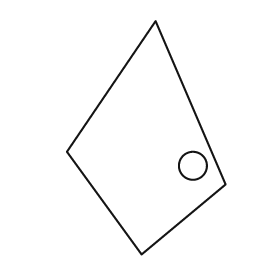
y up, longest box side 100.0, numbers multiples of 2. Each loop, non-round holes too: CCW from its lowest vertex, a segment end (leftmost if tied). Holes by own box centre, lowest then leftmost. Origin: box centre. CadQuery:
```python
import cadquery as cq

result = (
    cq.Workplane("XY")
    .moveTo(-2.0, -50.0)
    .lineTo(34.0, -20.0)
    .lineTo(4.0, 50.0)
    .lineTo(-34.0, -6.0)
    .close()
    .moveTo(20.0, -12.0)
    .circle(6.0)
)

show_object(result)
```